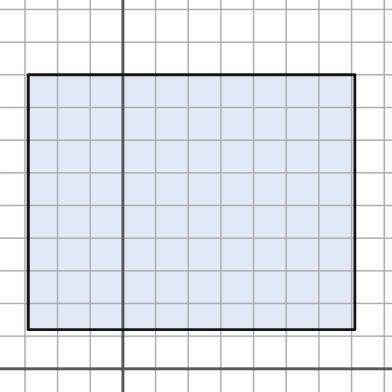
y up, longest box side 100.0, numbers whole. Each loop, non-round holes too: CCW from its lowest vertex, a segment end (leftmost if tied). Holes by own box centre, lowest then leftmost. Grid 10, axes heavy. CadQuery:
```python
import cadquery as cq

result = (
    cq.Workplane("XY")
    .moveTo(-29.0, 12.0)
    .lineTo(71.0, 12.0)
    .lineTo(71.0, 90.0)
    .lineTo(-29.0, 90.0)
    .close()
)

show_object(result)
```